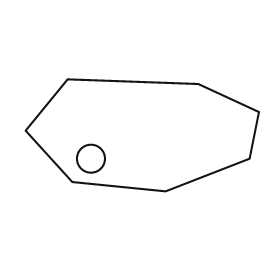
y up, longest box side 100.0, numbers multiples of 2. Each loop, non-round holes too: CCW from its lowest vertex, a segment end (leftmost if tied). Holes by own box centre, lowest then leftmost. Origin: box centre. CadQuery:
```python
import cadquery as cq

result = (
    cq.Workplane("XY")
    .moveTo(10.0, -24.0)
    .lineTo(46.0, -10.0)
    .lineTo(50.0, 10.0)
    .lineTo(24.0, 22.0)
    .lineTo(-32.0, 24.0)
    .lineTo(-50.0, 2.0)
    .lineTo(-30.0, -20.0)
    .close()
    .moveTo(-22.0, -10.0)
    .circle(6.0)
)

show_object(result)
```